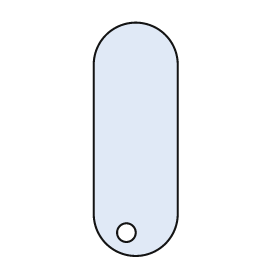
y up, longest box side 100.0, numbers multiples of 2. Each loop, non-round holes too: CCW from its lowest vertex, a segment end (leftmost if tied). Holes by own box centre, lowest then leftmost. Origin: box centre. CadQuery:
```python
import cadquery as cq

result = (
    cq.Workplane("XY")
    .moveTo(-18.0, -32.0)
    .threePointArc((0.0, -50.0), (18.0, -32.0))
    .lineTo(18.0, 32.0)
    .threePointArc((0.0, 50.0), (-18.0, 32.0))
    .close()
    .moveTo(-4.0, -40.0)
    .circle(4.0)
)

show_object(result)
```